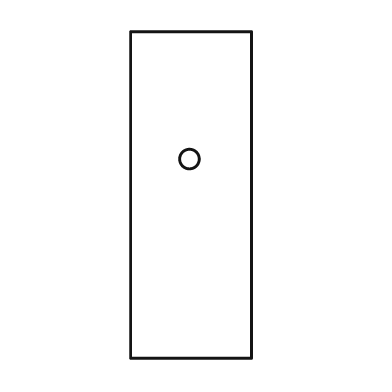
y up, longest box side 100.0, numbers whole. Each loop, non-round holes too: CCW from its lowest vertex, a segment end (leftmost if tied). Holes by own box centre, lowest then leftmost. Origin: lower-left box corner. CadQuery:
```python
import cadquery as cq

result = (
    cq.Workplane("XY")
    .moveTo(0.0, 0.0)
    .lineTo(37.0, 0.0)
    .lineTo(37.0, 100.0)
    .lineTo(0.0, 100.0)
    .close()
    .moveTo(18.0, 61.0)
    .circle(3.0)
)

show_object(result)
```